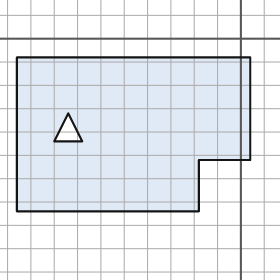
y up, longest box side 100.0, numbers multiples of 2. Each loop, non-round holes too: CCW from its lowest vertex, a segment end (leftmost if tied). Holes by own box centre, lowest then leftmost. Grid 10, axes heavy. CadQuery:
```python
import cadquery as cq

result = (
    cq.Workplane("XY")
    .moveTo(-96.0, -74.0)
    .lineTo(-18.0, -74.0)
    .lineTo(-18.0, -52.0)
    .lineTo(4.0, -52.0)
    .lineTo(4.0, -8.0)
    .lineTo(-96.0, -8.0)
    .close()
    .moveTo(-80.0, -44.0)
    .lineTo(-68.0, -44.0)
    .lineTo(-74.0, -32.0)
    .close()
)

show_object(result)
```